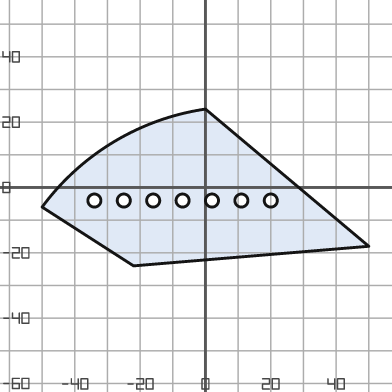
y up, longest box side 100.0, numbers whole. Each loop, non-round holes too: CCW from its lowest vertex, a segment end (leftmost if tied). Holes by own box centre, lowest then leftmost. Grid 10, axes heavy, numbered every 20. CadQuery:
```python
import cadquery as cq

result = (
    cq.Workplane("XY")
    .moveTo(-22.0, -24.0)
    .lineTo(50.0, -18.0)
    .lineTo(0.0, 24.0)
    .threePointArc((-28.0, 14.0), (-50.0, -6.0))
    .close()
    .moveTo(-34.0, -4.0)
    .circle(2.0)
    .moveTo(-25.0, -4.0)
    .circle(2.0)
    .moveTo(-16.0, -4.0)
    .circle(2.0)
    .moveTo(-7.0, -4.0)
    .circle(2.0)
    .moveTo(2.0, -4.0)
    .circle(2.0)
    .moveTo(11.0, -4.0)
    .circle(2.0)
    .moveTo(20.0, -4.0)
    .circle(2.0)
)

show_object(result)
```